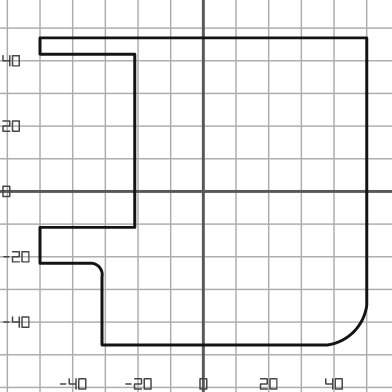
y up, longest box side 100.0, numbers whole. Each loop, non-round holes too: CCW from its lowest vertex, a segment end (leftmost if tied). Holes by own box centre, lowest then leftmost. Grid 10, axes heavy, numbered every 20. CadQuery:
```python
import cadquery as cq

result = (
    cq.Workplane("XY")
    .moveTo(-31.0, -47.0)
    .lineTo(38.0, -47.0)
    .threePointArc((46.0, -43.0), (50.0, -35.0))
    .lineTo(50.0, 47.0)
    .lineTo(-50.0, 47.0)
    .lineTo(-50.0, 42.0)
    .lineTo(-21.0, 42.0)
    .lineTo(-21.0, -11.0)
    .lineTo(-50.0, -11.0)
    .lineTo(-50.0, -22.0)
    .lineTo(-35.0, -22.0)
    .threePointArc((-32.0, -23.0), (-31.0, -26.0))
    .close()
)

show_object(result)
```